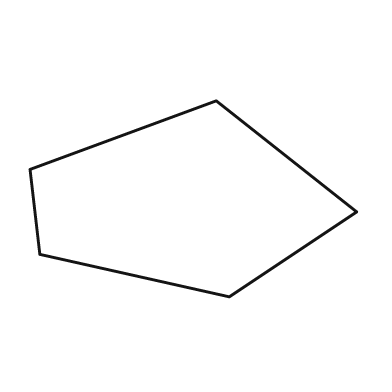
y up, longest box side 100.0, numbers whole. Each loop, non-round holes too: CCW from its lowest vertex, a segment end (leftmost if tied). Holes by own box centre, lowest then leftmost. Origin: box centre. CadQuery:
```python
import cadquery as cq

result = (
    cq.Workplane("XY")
    .moveTo(11.0, -30.0)
    .lineTo(50.0, -4.0)
    .lineTo(7.0, 30.0)
    .lineTo(-50.0, 9.0)
    .lineTo(-47.0, -17.0)
    .close()
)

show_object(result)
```